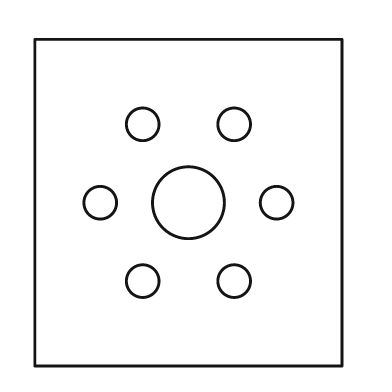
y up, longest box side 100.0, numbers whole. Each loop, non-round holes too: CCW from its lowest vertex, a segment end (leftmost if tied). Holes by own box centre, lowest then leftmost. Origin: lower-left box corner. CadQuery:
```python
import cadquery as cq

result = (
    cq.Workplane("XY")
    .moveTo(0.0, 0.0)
    .lineTo(94.0, 0.0)
    .lineTo(94.0, 100.0)
    .lineTo(0.0, 100.0)
    .close()
    .moveTo(33.0, 26.0)
    .circle(5.0)
    .moveTo(61.0, 26.0)
    .circle(5.0)
    .moveTo(20.0, 50.0)
    .circle(5.0)
    .moveTo(47.0, 50.0)
    .circle(11.0)
    .moveTo(74.0, 50.0)
    .circle(5.0)
    .moveTo(33.0, 74.0)
    .circle(5.0)
    .moveTo(61.0, 74.0)
    .circle(5.0)
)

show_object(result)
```